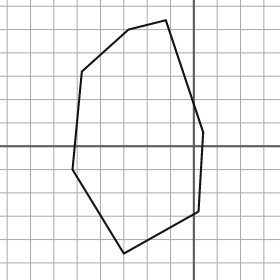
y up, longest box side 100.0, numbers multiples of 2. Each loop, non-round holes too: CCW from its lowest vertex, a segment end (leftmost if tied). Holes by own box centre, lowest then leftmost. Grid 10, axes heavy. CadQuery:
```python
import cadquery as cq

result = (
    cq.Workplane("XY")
    .moveTo(-30.0, -46.0)
    .lineTo(2.0, -28.0)
    .lineTo(4.0, 6.0)
    .lineTo(-12.0, 54.0)
    .lineTo(-28.0, 50.0)
    .lineTo(-48.0, 32.0)
    .lineTo(-52.0, -10.0)
    .close()
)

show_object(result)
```